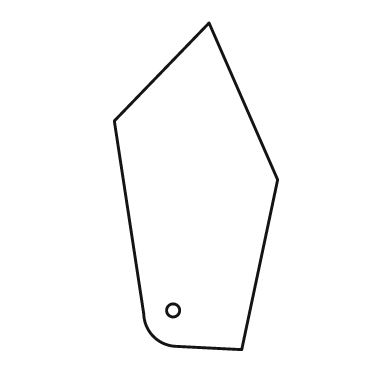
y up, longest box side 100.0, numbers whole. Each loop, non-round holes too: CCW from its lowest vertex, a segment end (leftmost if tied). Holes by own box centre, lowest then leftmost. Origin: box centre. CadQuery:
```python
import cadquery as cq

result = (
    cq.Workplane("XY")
    .moveTo(14.0, -50.0)
    .lineTo(25.0, 2.0)
    .lineTo(4.0, 50.0)
    .lineTo(-25.0, 20.0)
    .lineTo(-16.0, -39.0)
    .threePointArc((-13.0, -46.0), (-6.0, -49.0))
    .close()
    .moveTo(-7.0, -38.0)
    .circle(2.0)
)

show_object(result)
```